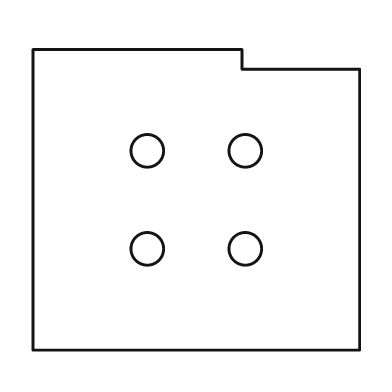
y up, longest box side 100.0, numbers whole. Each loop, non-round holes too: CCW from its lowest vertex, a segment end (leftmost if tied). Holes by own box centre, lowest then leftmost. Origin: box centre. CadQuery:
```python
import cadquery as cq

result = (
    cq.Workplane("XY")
    .moveTo(-50.0, -46.0)
    .lineTo(50.0, -46.0)
    .lineTo(50.0, 40.0)
    .lineTo(14.0, 40.0)
    .lineTo(14.0, 46.0)
    .lineTo(-50.0, 46.0)
    .close()
    .moveTo(-15.0, -15.0)
    .circle(5.0)
    .moveTo(15.0, -15.0)
    .circle(5.0)
    .moveTo(-15.0, 15.0)
    .circle(5.0)
    .moveTo(15.0, 15.0)
    .circle(5.0)
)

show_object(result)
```